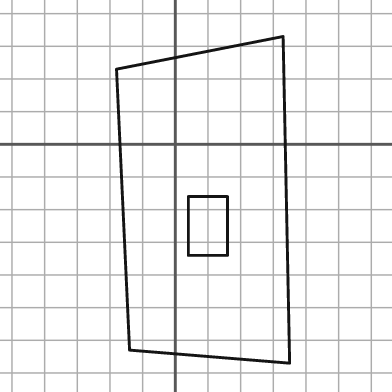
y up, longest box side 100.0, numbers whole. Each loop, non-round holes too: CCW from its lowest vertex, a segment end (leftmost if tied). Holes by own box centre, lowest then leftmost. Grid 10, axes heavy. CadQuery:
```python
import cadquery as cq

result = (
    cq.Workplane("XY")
    .moveTo(35.0, -67.0)
    .lineTo(33.0, 33.0)
    .lineTo(-18.0, 23.0)
    .lineTo(-14.0, -63.0)
    .close()
    .moveTo(4.0, -34.0)
    .lineTo(16.0, -34.0)
    .lineTo(16.0, -16.0)
    .lineTo(4.0, -16.0)
    .close()
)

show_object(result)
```